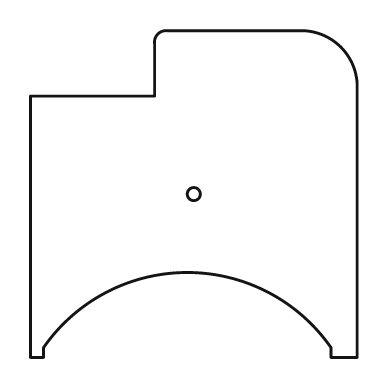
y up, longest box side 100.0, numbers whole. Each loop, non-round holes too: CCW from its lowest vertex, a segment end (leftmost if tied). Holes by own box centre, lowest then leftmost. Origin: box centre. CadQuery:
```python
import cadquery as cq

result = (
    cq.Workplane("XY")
    .moveTo(-50.0, -50.0)
    .lineTo(-46.0, -50.0)
    .lineTo(-46.0, -47.0)
    .threePointArc((-2.0, -24.0), (42.0, -47.0))
    .lineTo(42.0, -50.0)
    .lineTo(50.0, -50.0)
    .lineTo(50.0, 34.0)
    .threePointArc((45.0, 45.0), (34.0, 50.0))
    .lineTo(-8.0, 50.0)
    .threePointArc((-11.0, 49.0), (-12.0, 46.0))
    .lineTo(-12.0, 30.0)
    .lineTo(-50.0, 30.0)
    .close()
    .moveTo(0.0, 0.0)
    .circle(2.0)
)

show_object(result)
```